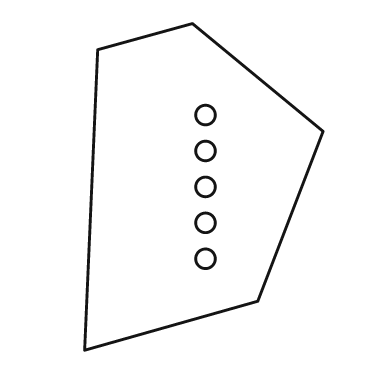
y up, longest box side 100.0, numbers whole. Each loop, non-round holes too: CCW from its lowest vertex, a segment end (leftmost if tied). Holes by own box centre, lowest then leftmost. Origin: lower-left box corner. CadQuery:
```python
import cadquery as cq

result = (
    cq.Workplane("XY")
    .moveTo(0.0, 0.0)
    .lineTo(53.0, 15.0)
    .lineTo(73.0, 67.0)
    .lineTo(33.0, 100.0)
    .lineTo(4.0, 92.0)
    .close()
    .moveTo(37.0, 28.0)
    .circle(3.0)
    .moveTo(37.0, 39.0)
    .circle(3.0)
    .moveTo(37.0, 50.0)
    .circle(3.0)
    .moveTo(37.0, 61.0)
    .circle(3.0)
    .moveTo(37.0, 72.0)
    .circle(3.0)
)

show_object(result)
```